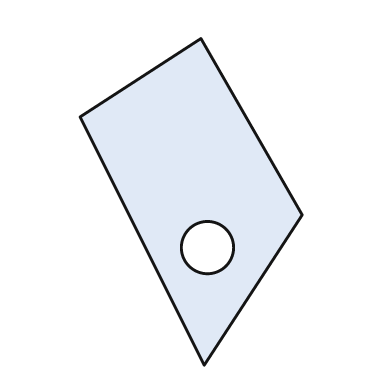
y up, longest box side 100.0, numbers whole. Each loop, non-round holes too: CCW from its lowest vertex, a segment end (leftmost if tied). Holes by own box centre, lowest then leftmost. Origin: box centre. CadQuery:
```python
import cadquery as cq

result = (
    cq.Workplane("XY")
    .moveTo(4.0, -50.0)
    .lineTo(34.0, -4.0)
    .lineTo(3.0, 50.0)
    .lineTo(-34.0, 26.0)
    .close()
    .moveTo(5.0, -14.0)
    .circle(8.0)
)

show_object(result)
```